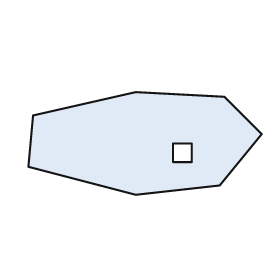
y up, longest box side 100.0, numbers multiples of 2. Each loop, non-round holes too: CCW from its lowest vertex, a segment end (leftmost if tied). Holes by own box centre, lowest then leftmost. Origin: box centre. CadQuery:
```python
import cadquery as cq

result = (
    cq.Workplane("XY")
    .moveTo(-4.0, -22.0)
    .lineTo(32.0, -18.0)
    .lineTo(50.0, 4.0)
    .lineTo(34.0, 20.0)
    .lineTo(-4.0, 22.0)
    .lineTo(-48.0, 12.0)
    .lineTo(-50.0, -10.0)
    .close()
    .moveTo(12.0, -8.0)
    .lineTo(20.0, -8.0)
    .lineTo(20.0, 0.0)
    .lineTo(12.0, 0.0)
    .close()
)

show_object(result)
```